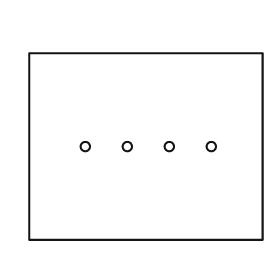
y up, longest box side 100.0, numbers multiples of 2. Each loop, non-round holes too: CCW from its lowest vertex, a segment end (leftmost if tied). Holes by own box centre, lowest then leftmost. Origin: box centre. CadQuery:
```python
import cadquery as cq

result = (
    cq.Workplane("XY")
    .moveTo(-50.0, -40.0)
    .lineTo(50.0, -40.0)
    .lineTo(50.0, 40.0)
    .lineTo(-50.0, 40.0)
    .close()
    .moveTo(-26.0, 0.0)
    .circle(2.0)
    .moveTo(-8.0, 0.0)
    .circle(2.0)
    .moveTo(10.0, 0.0)
    .circle(2.0)
    .moveTo(28.0, 0.0)
    .circle(2.0)
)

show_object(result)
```